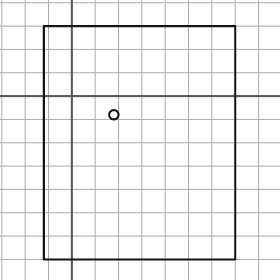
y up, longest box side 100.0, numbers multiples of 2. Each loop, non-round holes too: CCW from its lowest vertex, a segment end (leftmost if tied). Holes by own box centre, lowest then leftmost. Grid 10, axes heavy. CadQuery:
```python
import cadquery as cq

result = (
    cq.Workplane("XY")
    .moveTo(-12.0, -70.0)
    .lineTo(70.0, -70.0)
    .lineTo(70.0, 30.0)
    .lineTo(-12.0, 30.0)
    .close()
    .moveTo(18.0, -8.0)
    .circle(2.0)
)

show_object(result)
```